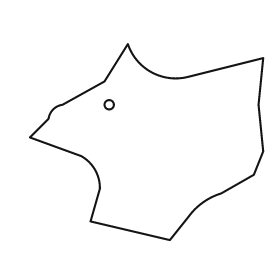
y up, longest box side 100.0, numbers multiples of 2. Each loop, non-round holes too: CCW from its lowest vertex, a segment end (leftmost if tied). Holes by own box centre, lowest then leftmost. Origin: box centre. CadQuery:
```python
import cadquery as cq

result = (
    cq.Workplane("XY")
    .moveTo(10.0, -42.0)
    .lineTo(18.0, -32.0)
    .threePointArc((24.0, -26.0), (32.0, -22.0))
    .lineTo(46.0, -14.0)
    .lineTo(50.0, -4.0)
    .lineTo(48.0, 16.0)
    .lineTo(50.0, 36.0)
    .lineTo(18.0, 28.0)
    .threePointArc((2.0, 30.0), (-8.0, 42.0))
    .lineTo(-18.0, 26.0)
    .lineTo(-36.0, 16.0)
    .threePointArc((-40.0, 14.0), (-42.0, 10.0))
    .lineTo(-50.0, 2.0)
    .lineTo(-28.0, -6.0)
    .threePointArc((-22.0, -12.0), (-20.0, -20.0))
    .lineTo(-24.0, -34.0)
    .close()
    .moveTo(-16.0, 16.0)
    .circle(2.0)
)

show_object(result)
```